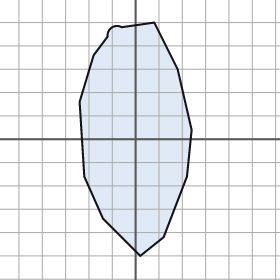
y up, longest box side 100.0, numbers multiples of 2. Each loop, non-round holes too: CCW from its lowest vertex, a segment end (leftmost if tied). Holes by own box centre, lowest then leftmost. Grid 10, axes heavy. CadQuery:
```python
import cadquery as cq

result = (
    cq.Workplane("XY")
    .moveTo(2.0, -50.0)
    .lineTo(12.0, -42.0)
    .lineTo(22.0, -16.0)
    .lineTo(24.0, 4.0)
    .lineTo(18.0, 30.0)
    .lineTo(8.0, 50.0)
    .lineTo(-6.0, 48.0)
    .threePointArc((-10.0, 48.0), (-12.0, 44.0))
    .lineTo(-18.0, 36.0)
    .lineTo(-24.0, 16.0)
    .lineTo(-22.0, -16.0)
    .lineTo(-14.0, -34.0)
    .close()
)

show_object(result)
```